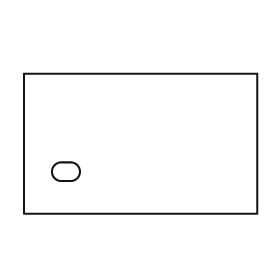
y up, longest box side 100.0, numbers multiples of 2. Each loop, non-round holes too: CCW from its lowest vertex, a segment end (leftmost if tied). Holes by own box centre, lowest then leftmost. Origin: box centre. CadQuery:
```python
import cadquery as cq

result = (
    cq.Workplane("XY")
    .moveTo(-50.0, -30.0)
    .lineTo(50.0, -30.0)
    .lineTo(50.0, 30.0)
    .lineTo(-50.0, 30.0)
    .close()
    .moveTo(-34.0, -16.0)
    .lineTo(-30.0, -16.0)
    .threePointArc((-26.0, -12.0), (-30.0, -8.0))
    .lineTo(-34.0, -8.0)
    .threePointArc((-38.0, -12.0), (-34.0, -16.0))
    .close()
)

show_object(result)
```